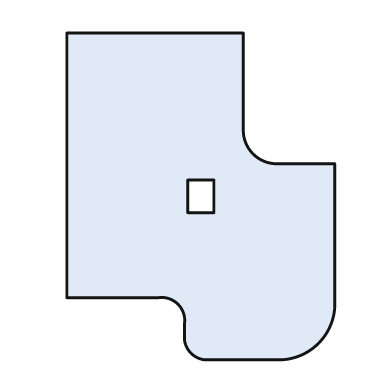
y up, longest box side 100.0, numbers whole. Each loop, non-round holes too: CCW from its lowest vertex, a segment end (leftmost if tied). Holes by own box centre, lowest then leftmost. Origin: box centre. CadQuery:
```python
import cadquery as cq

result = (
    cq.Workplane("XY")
    .moveTo(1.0, -50.0)
    .lineTo(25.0, -50.0)
    .threePointArc((36.0, -45.0), (41.0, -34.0))
    .lineTo(41.0, 10.0)
    .lineTo(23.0, 10.0)
    .threePointArc((16.0, 13.0), (13.0, 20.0))
    .lineTo(13.0, 50.0)
    .lineTo(-41.0, 50.0)
    .lineTo(-41.0, -31.0)
    .lineTo(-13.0, -31.0)
    .threePointArc((-7.0, -33.0), (-5.0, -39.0))
    .lineTo(-5.0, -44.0)
    .threePointArc((-3.0, -48.0), (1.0, -50.0))
    .close()
    .moveTo(-4.0, -5.0)
    .lineTo(4.0, -5.0)
    .lineTo(4.0, 5.0)
    .lineTo(-4.0, 5.0)
    .close()
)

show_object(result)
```